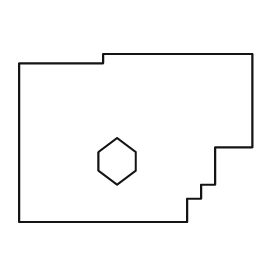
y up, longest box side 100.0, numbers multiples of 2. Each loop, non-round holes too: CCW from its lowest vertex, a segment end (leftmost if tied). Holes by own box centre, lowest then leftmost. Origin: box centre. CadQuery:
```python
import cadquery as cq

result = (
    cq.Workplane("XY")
    .moveTo(-50.0, -36.0)
    .lineTo(22.0, -36.0)
    .lineTo(22.0, -26.0)
    .lineTo(28.0, -26.0)
    .lineTo(28.0, -20.0)
    .lineTo(34.0, -20.0)
    .lineTo(34.0, -4.0)
    .lineTo(50.0, -4.0)
    .lineTo(50.0, 36.0)
    .lineTo(-14.0, 36.0)
    .lineTo(-14.0, 32.0)
    .lineTo(-50.0, 32.0)
    .close()
    .moveTo(-8.0, -20.0)
    .lineTo(0.0, -14.0)
    .lineTo(0.0, -6.0)
    .lineTo(-8.0, 0.0)
    .lineTo(-16.0, -6.0)
    .lineTo(-16.0, -14.0)
    .close()
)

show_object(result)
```